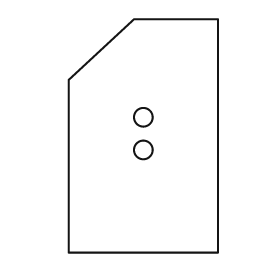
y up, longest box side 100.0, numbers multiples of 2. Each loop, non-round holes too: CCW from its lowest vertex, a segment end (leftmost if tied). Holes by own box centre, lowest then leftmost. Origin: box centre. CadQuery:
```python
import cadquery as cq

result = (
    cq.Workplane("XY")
    .moveTo(-32.0, -50.0)
    .lineTo(32.0, -50.0)
    .lineTo(32.0, 50.0)
    .lineTo(-4.0, 50.0)
    .lineTo(-32.0, 24.0)
    .close()
    .moveTo(0.0, -6.0)
    .circle(4.0)
    .moveTo(0.0, 8.0)
    .circle(4.0)
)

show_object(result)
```